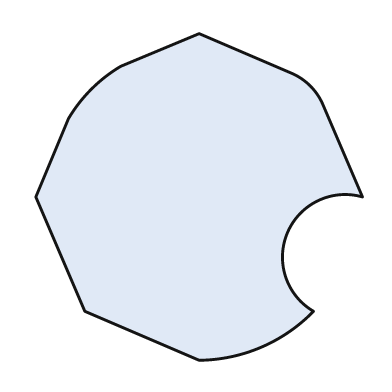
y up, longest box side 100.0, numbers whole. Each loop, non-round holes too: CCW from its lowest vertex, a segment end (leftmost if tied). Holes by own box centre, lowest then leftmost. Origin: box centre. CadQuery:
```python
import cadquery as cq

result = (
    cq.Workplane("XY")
    .moveTo(0.0, -50.0)
    .threePointArc((19.0, -46.0), (35.0, -35.0))
    .threePointArc((27.0, -11.0), (50.0, 0.0))
    .lineTo(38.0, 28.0)
    .threePointArc((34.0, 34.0), (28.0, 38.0))
    .lineTo(0.0, 50.0)
    .lineTo(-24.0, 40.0)
    .threePointArc((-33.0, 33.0), (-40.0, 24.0))
    .lineTo(-50.0, 0.0)
    .lineTo(-35.0, -35.0)
    .close()
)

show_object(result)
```